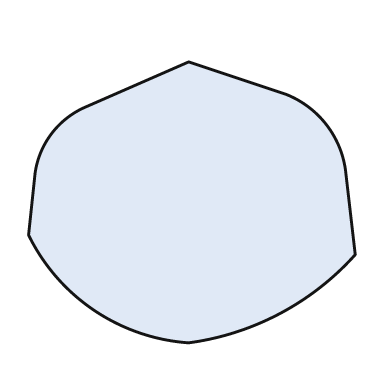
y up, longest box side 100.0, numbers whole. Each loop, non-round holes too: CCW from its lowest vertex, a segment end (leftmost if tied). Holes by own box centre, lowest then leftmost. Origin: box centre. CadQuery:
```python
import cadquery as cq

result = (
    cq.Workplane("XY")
    .moveTo(-1.0, -43.0)
    .threePointArc((27.0, -34.0), (50.0, -16.0))
    .lineTo(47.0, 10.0)
    .threePointArc((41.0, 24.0), (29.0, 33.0))
    .lineTo(-1.0, 43.0)
    .lineTo(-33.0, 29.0)
    .threePointArc((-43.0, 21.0), (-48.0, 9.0))
    .lineTo(-50.0, -10.0)
    .threePointArc((-30.0, -33.0), (-1.0, -43.0))
    .close()
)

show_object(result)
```